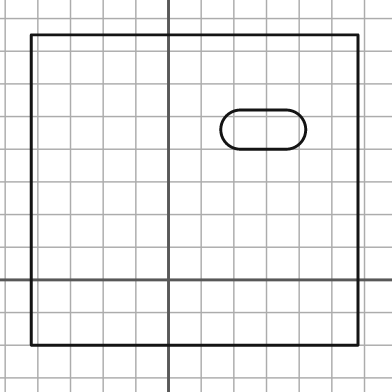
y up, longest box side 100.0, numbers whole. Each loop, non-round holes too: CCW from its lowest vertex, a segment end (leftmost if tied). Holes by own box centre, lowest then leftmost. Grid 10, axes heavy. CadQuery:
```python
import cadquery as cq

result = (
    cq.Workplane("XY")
    .moveTo(-42.0, -20.0)
    .lineTo(58.0, -20.0)
    .lineTo(58.0, 75.0)
    .lineTo(-42.0, 75.0)
    .close()
    .moveTo(22.0, 40.0)
    .lineTo(36.0, 40.0)
    .threePointArc((42.0, 46.0), (36.0, 52.0))
    .lineTo(22.0, 52.0)
    .threePointArc((16.0, 46.0), (22.0, 40.0))
    .close()
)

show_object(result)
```